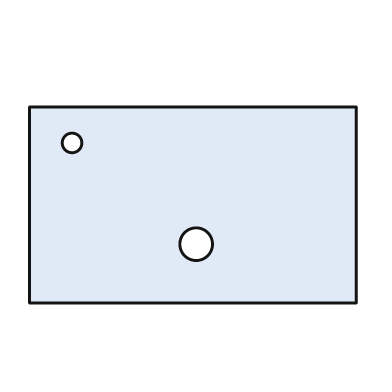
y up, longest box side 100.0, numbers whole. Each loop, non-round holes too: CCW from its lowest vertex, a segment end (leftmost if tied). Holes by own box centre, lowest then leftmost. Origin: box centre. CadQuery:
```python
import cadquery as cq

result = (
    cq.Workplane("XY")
    .moveTo(-50.0, -30.0)
    .lineTo(50.0, -30.0)
    .lineTo(50.0, 30.0)
    .lineTo(-50.0, 30.0)
    .close()
    .moveTo(1.0, -12.0)
    .circle(5.0)
    .moveTo(-37.0, 19.0)
    .circle(3.0)
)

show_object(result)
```